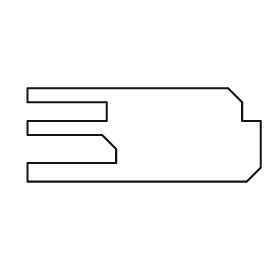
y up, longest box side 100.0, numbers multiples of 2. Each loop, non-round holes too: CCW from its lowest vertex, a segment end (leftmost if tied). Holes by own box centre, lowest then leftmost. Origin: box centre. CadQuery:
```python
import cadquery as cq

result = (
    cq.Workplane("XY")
    .moveTo(-50.0, -20.0)
    .lineTo(44.0, -20.0)
    .lineTo(50.0, -14.0)
    .lineTo(50.0, 6.0)
    .lineTo(42.0, 6.0)
    .lineTo(42.0, 14.0)
    .lineTo(36.0, 20.0)
    .lineTo(-50.0, 20.0)
    .lineTo(-50.0, 14.0)
    .lineTo(-16.0, 14.0)
    .lineTo(-16.0, 6.0)
    .lineTo(-50.0, 6.0)
    .lineTo(-50.0, 0.0)
    .lineTo(-18.0, 0.0)
    .lineTo(-12.0, -6.0)
    .lineTo(-12.0, -12.0)
    .lineTo(-50.0, -12.0)
    .close()
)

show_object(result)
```